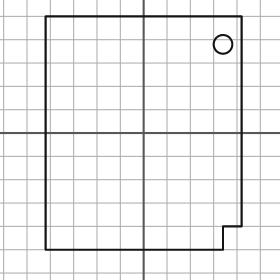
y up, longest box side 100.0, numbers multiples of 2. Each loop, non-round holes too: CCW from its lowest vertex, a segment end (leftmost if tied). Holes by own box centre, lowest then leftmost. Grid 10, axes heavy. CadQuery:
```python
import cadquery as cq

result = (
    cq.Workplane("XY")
    .moveTo(-42.0, -50.0)
    .lineTo(34.0, -50.0)
    .lineTo(34.0, -40.0)
    .lineTo(42.0, -40.0)
    .lineTo(42.0, 50.0)
    .lineTo(-42.0, 50.0)
    .close()
    .moveTo(34.0, 38.0)
    .circle(4.0)
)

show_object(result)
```